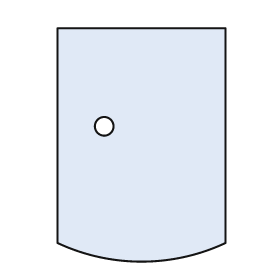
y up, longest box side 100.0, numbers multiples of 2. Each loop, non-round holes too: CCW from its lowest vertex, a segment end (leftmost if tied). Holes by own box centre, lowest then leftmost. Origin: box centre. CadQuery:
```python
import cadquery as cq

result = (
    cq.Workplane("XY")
    .moveTo(-36.0, -42.0)
    .threePointArc((0.0, -50.0), (36.0, -42.0))
    .lineTo(36.0, 50.0)
    .lineTo(-36.0, 50.0)
    .close()
    .moveTo(-16.0, 8.0)
    .circle(4.0)
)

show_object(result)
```